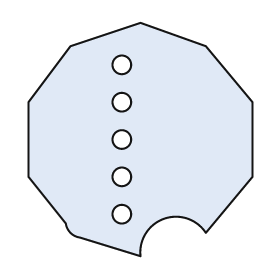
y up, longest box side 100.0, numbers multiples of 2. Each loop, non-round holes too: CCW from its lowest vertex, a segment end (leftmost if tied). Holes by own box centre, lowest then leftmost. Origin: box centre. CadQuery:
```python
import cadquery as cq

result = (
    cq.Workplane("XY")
    .moveTo(0.0, -50.0)
    .threePointArc((10.0, -34.0), (28.0, -40.0))
    .lineTo(48.0, -16.0)
    .lineTo(48.0, 16.0)
    .lineTo(28.0, 40.0)
    .lineTo(0.0, 50.0)
    .lineTo(-30.0, 40.0)
    .lineTo(-48.0, 16.0)
    .lineTo(-48.0, -16.0)
    .lineTo(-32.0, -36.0)
    .threePointArc((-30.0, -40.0), (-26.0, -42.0))
    .close()
    .moveTo(-8.0, -32.0)
    .circle(4.0)
    .moveTo(-8.0, -16.0)
    .circle(4.0)
    .moveTo(-8.0, 0.0)
    .circle(4.0)
    .moveTo(-8.0, 16.0)
    .circle(4.0)
    .moveTo(-8.0, 32.0)
    .circle(4.0)
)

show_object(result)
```